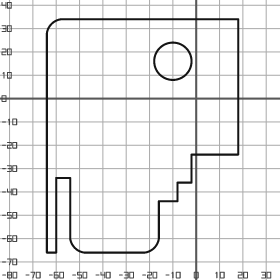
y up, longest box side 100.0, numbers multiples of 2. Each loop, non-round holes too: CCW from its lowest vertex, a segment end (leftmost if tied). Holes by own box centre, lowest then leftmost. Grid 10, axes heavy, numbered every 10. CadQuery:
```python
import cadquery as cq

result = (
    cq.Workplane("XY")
    .moveTo(-64.0, -66.0)
    .lineTo(-60.0, -66.0)
    .lineTo(-60.0, -34.0)
    .lineTo(-54.0, -34.0)
    .lineTo(-54.0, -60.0)
    .threePointArc((-52.0, -64.0), (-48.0, -66.0))
    .lineTo(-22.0, -66.0)
    .threePointArc((-18.0, -64.0), (-16.0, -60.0))
    .lineTo(-16.0, -44.0)
    .lineTo(-8.0, -44.0)
    .lineTo(-8.0, -36.0)
    .lineTo(-2.0, -36.0)
    .lineTo(-2.0, -24.0)
    .lineTo(18.0, -24.0)
    .lineTo(18.0, 34.0)
    .lineTo(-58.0, 34.0)
    .threePointArc((-62.0, 32.0), (-64.0, 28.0))
    .close()
    .moveTo(-10.0, 16.0)
    .circle(8.0)
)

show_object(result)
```